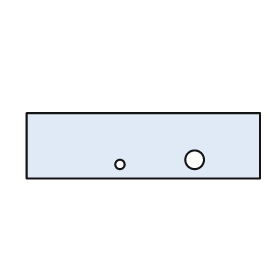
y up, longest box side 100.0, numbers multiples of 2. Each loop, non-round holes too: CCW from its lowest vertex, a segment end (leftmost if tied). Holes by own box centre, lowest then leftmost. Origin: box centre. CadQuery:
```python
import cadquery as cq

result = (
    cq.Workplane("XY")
    .moveTo(-50.0, -14.0)
    .lineTo(50.0, -14.0)
    .lineTo(50.0, 14.0)
    .lineTo(-50.0, 14.0)
    .close()
    .moveTo(-10.0, -8.0)
    .circle(2.0)
    .moveTo(22.0, -6.0)
    .circle(4.0)
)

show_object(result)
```